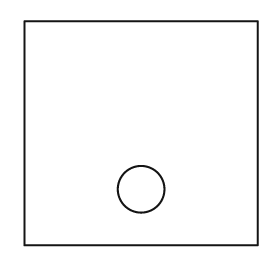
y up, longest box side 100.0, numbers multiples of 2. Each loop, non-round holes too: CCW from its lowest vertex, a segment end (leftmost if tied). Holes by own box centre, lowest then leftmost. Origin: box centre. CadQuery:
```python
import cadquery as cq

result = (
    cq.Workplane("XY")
    .moveTo(-50.0, -48.0)
    .lineTo(50.0, -48.0)
    .lineTo(50.0, 48.0)
    .lineTo(-50.0, 48.0)
    .close()
    .moveTo(0.0, -24.0)
    .circle(10.0)
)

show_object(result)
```